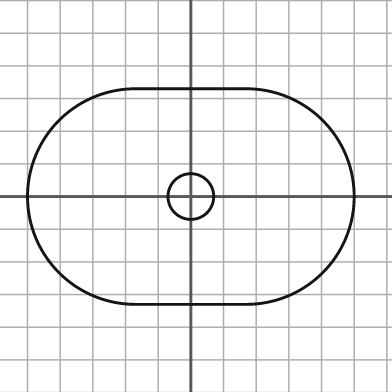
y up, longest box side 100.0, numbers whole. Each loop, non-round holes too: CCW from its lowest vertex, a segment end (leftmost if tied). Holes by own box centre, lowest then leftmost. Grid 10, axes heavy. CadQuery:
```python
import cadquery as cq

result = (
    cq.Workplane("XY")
    .moveTo(-17.0, -33.0)
    .lineTo(17.0, -33.0)
    .threePointArc((50.0, 0.0), (17.0, 33.0))
    .lineTo(-17.0, 33.0)
    .threePointArc((-50.0, 0.0), (-17.0, -33.0))
    .close()
    .moveTo(0.0, 0.0)
    .circle(7.0)
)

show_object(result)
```